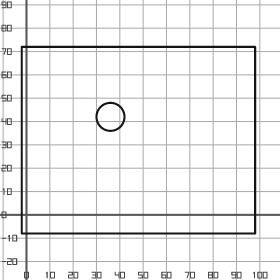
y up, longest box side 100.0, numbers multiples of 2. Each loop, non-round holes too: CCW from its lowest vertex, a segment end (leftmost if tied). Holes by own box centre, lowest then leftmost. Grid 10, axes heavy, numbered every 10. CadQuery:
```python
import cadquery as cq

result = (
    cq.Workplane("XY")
    .moveTo(-2.0, -8.0)
    .lineTo(98.0, -8.0)
    .lineTo(98.0, 72.0)
    .lineTo(-2.0, 72.0)
    .close()
    .moveTo(36.0, 42.0)
    .circle(6.0)
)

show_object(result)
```